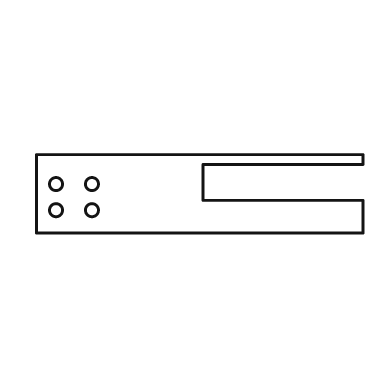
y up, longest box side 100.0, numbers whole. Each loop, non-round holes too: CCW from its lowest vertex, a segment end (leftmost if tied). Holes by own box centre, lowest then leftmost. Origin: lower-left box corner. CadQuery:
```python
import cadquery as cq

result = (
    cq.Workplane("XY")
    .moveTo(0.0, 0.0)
    .lineTo(100.0, 0.0)
    .lineTo(100.0, 10.0)
    .lineTo(51.0, 10.0)
    .lineTo(51.0, 21.0)
    .lineTo(100.0, 21.0)
    .lineTo(100.0, 24.0)
    .lineTo(0.0, 24.0)
    .close()
    .moveTo(6.0, 7.0)
    .circle(2.0)
    .moveTo(17.0, 7.0)
    .circle(2.0)
    .moveTo(6.0, 15.0)
    .circle(2.0)
    .moveTo(17.0, 15.0)
    .circle(2.0)
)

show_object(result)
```